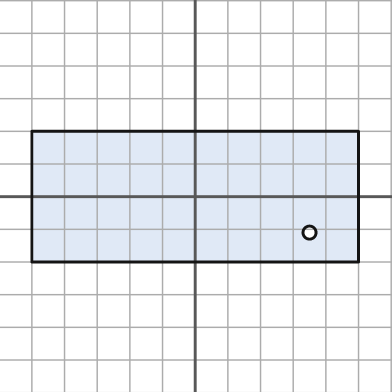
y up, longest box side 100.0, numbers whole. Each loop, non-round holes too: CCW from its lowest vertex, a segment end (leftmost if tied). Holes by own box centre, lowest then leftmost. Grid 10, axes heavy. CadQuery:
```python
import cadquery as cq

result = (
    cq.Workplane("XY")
    .moveTo(-50.0, -20.0)
    .lineTo(50.0, -20.0)
    .lineTo(50.0, 20.0)
    .lineTo(-50.0, 20.0)
    .close()
    .moveTo(35.0, -11.0)
    .circle(2.0)
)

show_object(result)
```